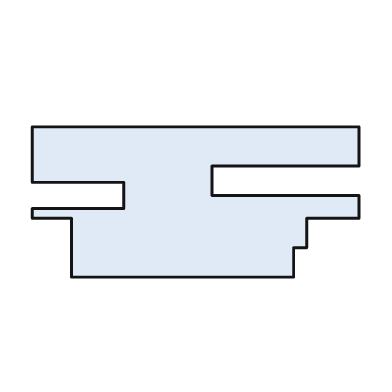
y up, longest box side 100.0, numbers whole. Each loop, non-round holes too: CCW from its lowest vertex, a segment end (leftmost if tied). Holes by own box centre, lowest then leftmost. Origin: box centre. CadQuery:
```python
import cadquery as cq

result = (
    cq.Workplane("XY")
    .moveTo(-38.0, -23.0)
    .lineTo(30.0, -23.0)
    .lineTo(30.0, -14.0)
    .lineTo(34.0, -14.0)
    .lineTo(34.0, -5.0)
    .lineTo(50.0, -5.0)
    .lineTo(50.0, 2.0)
    .lineTo(5.0, 2.0)
    .lineTo(5.0, 11.0)
    .lineTo(50.0, 11.0)
    .lineTo(50.0, 23.0)
    .lineTo(-50.0, 23.0)
    .lineTo(-50.0, 6.0)
    .lineTo(-22.0, 6.0)
    .lineTo(-22.0, -2.0)
    .lineTo(-50.0, -2.0)
    .lineTo(-50.0, -5.0)
    .lineTo(-38.0, -5.0)
    .close()
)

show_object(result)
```